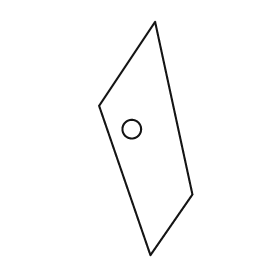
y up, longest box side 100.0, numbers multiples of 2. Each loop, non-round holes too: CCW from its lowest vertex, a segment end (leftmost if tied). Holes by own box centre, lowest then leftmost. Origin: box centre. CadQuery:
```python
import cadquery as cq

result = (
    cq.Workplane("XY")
    .moveTo(2.0, -50.0)
    .lineTo(20.0, -24.0)
    .lineTo(4.0, 50.0)
    .lineTo(-20.0, 14.0)
    .close()
    .moveTo(-6.0, 4.0)
    .circle(4.0)
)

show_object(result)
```